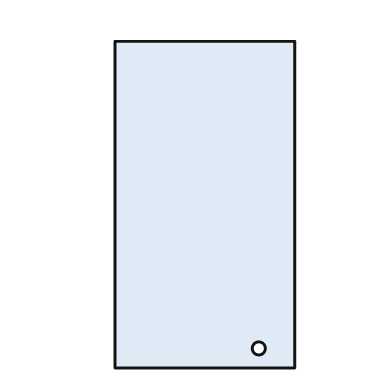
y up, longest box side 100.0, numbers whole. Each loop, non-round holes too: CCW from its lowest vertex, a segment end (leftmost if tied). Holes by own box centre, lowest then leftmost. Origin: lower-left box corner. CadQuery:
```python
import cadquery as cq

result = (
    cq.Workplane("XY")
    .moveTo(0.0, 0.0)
    .lineTo(55.0, 0.0)
    .lineTo(55.0, 100.0)
    .lineTo(0.0, 100.0)
    .close()
    .moveTo(44.0, 6.0)
    .circle(2.0)
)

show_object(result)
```